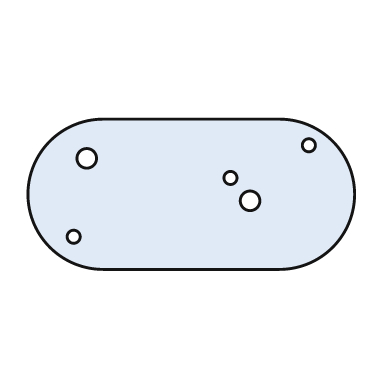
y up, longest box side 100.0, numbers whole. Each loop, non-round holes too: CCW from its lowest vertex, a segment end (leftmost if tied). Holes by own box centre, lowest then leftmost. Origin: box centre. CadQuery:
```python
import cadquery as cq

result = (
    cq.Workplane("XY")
    .moveTo(-27.0, -23.0)
    .lineTo(27.0, -23.0)
    .threePointArc((50.0, 0.0), (27.0, 23.0))
    .lineTo(-27.0, 23.0)
    .threePointArc((-50.0, 0.0), (-27.0, -23.0))
    .close()
    .moveTo(-36.0, -13.0)
    .circle(2.0)
    .moveTo(18.0, -2.0)
    .circle(3.0)
    .moveTo(12.0, 5.0)
    .circle(2.0)
    .moveTo(-32.0, 11.0)
    .circle(3.0)
    .moveTo(36.0, 15.0)
    .circle(2.0)
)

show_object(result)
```